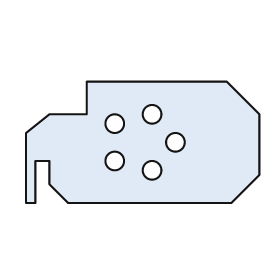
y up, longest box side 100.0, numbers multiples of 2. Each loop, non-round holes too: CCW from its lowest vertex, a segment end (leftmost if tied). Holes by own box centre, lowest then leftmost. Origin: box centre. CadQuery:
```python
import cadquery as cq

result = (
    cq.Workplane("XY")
    .moveTo(-50.0, -26.0)
    .lineTo(-46.0, -26.0)
    .lineTo(-46.0, -8.0)
    .lineTo(-40.0, -8.0)
    .lineTo(-40.0, -18.0)
    .lineTo(-32.0, -26.0)
    .lineTo(38.0, -26.0)
    .lineTo(50.0, -14.0)
    .lineTo(50.0, 12.0)
    .lineTo(36.0, 26.0)
    .lineTo(-24.0, 26.0)
    .lineTo(-24.0, 12.0)
    .lineTo(-40.0, 12.0)
    .lineTo(-50.0, 4.0)
    .close()
    .moveTo(4.0, -12.0)
    .circle(4.0)
    .moveTo(-12.0, -8.0)
    .circle(4.0)
    .moveTo(14.0, 0.0)
    .circle(4.0)
    .moveTo(-12.0, 8.0)
    .circle(4.0)
    .moveTo(4.0, 12.0)
    .circle(4.0)
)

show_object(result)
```